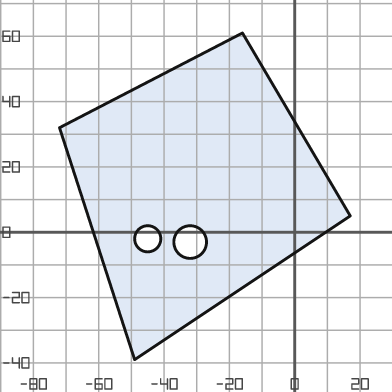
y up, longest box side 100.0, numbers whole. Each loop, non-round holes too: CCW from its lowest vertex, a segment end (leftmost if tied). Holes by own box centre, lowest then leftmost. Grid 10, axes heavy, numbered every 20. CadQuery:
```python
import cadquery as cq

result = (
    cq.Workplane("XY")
    .moveTo(-49.0, -39.0)
    .lineTo(17.0, 5.0)
    .lineTo(-16.0, 61.0)
    .lineTo(-72.0, 32.0)
    .close()
    .moveTo(-32.0, -3.0)
    .circle(5.0)
    .moveTo(-45.0, -2.0)
    .circle(4.0)
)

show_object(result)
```